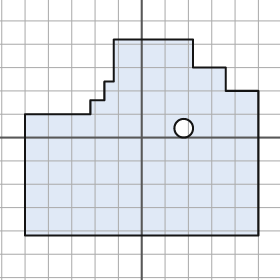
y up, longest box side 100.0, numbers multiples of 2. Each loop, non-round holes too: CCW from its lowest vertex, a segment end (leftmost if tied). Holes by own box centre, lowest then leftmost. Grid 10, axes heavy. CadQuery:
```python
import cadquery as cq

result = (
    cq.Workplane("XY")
    .moveTo(-50.0, -42.0)
    .lineTo(50.0, -42.0)
    .lineTo(50.0, 20.0)
    .lineTo(36.0, 20.0)
    .lineTo(36.0, 30.0)
    .lineTo(22.0, 30.0)
    .lineTo(22.0, 42.0)
    .lineTo(-12.0, 42.0)
    .lineTo(-12.0, 24.0)
    .lineTo(-16.0, 24.0)
    .lineTo(-16.0, 16.0)
    .lineTo(-22.0, 16.0)
    .lineTo(-22.0, 10.0)
    .lineTo(-50.0, 10.0)
    .close()
    .moveTo(18.0, 4.0)
    .circle(4.0)
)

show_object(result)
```